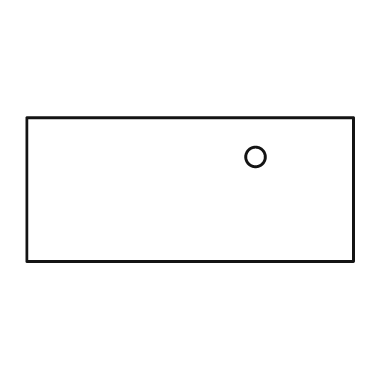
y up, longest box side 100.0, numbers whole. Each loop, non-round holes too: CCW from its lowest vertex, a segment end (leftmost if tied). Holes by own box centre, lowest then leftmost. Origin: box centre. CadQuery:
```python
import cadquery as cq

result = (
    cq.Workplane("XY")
    .moveTo(-50.0, -22.0)
    .lineTo(50.0, -22.0)
    .lineTo(50.0, 22.0)
    .lineTo(-50.0, 22.0)
    .close()
    .moveTo(20.0, 10.0)
    .circle(3.0)
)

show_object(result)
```